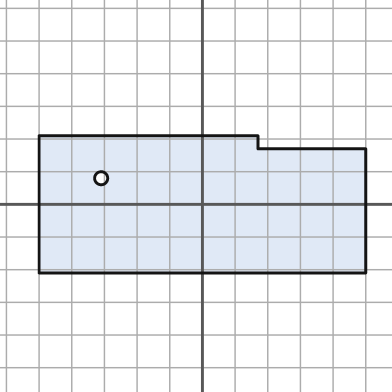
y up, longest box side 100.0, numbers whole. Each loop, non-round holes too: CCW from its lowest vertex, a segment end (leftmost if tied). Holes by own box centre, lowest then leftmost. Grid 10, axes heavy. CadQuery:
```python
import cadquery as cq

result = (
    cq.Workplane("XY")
    .moveTo(-50.0, -21.0)
    .lineTo(50.0, -21.0)
    .lineTo(50.0, 17.0)
    .lineTo(17.0, 17.0)
    .lineTo(17.0, 21.0)
    .lineTo(-50.0, 21.0)
    .close()
    .moveTo(-31.0, 8.0)
    .circle(2.0)
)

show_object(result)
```